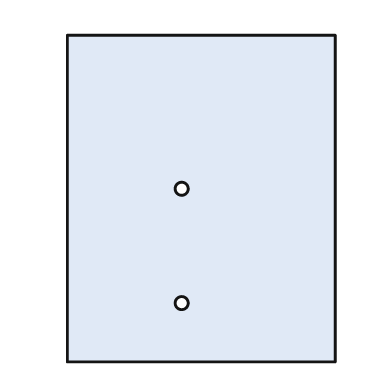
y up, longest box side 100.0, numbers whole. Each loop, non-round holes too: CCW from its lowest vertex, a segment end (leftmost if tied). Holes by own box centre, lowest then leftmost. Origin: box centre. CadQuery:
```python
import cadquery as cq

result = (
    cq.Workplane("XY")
    .moveTo(-41.0, -50.0)
    .lineTo(41.0, -50.0)
    .lineTo(41.0, 50.0)
    .lineTo(-41.0, 50.0)
    .close()
    .moveTo(-6.0, -32.0)
    .circle(2.0)
    .moveTo(-6.0, 3.0)
    .circle(2.0)
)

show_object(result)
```